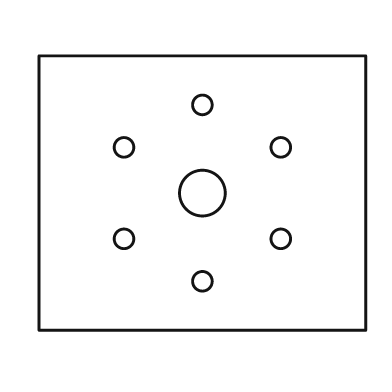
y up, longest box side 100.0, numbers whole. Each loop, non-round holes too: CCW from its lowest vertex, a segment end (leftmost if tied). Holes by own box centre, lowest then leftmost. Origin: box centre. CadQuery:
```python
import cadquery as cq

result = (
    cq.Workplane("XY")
    .moveTo(-50.0, -42.0)
    .lineTo(50.0, -42.0)
    .lineTo(50.0, 42.0)
    .lineTo(-50.0, 42.0)
    .close()
    .moveTo(0.0, -27.0)
    .circle(3.0)
    .moveTo(-24.0, -14.0)
    .circle(3.0)
    .moveTo(24.0, -14.0)
    .circle(3.0)
    .moveTo(0.0, 0.0)
    .circle(7.0)
    .moveTo(-24.0, 14.0)
    .circle(3.0)
    .moveTo(24.0, 14.0)
    .circle(3.0)
    .moveTo(0.0, 27.0)
    .circle(3.0)
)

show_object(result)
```